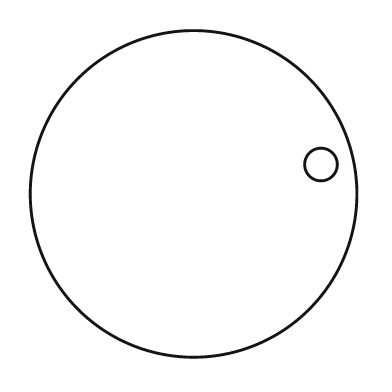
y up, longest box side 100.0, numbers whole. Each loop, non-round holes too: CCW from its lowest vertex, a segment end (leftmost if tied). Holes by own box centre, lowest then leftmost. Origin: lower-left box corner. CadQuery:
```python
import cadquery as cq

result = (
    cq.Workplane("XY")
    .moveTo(50.0, 50.0)
    .circle(50.0)
    .moveTo(89.0, 59.0)
    .circle(5.0)
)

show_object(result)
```